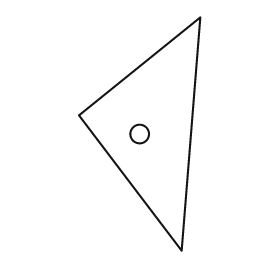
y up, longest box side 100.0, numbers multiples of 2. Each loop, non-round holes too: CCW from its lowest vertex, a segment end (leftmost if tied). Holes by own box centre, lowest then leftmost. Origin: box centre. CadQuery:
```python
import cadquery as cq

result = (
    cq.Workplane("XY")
    .moveTo(18.0, -50.0)
    .lineTo(26.0, 50.0)
    .lineTo(-26.0, 8.0)
    .close()
    .moveTo(0.0, 0.0)
    .circle(4.0)
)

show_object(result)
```